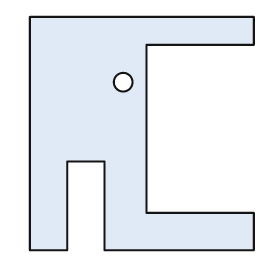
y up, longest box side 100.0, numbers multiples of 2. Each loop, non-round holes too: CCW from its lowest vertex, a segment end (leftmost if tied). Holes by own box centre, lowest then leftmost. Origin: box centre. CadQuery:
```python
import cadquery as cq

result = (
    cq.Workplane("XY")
    .moveTo(-48.0, -50.0)
    .lineTo(-32.0, -50.0)
    .lineTo(-32.0, -12.0)
    .lineTo(-16.0, -12.0)
    .lineTo(-16.0, -50.0)
    .lineTo(48.0, -50.0)
    .lineTo(48.0, -34.0)
    .lineTo(2.0, -34.0)
    .lineTo(2.0, 38.0)
    .lineTo(48.0, 38.0)
    .lineTo(48.0, 50.0)
    .lineTo(-48.0, 50.0)
    .close()
    .moveTo(-8.0, 22.0)
    .circle(4.0)
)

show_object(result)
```